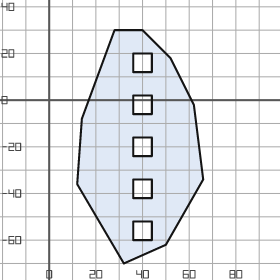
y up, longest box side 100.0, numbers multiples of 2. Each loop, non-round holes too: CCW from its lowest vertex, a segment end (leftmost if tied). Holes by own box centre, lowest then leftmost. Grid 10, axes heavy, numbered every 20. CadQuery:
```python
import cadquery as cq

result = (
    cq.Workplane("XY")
    .moveTo(32.0, -70.0)
    .lineTo(50.0, -62.0)
    .lineTo(66.0, -34.0)
    .lineTo(62.0, -2.0)
    .lineTo(52.0, 18.0)
    .lineTo(40.0, 30.0)
    .lineTo(28.0, 30.0)
    .lineTo(14.0, -8.0)
    .lineTo(12.0, -36.0)
    .close()
    .moveTo(36.0, -60.0)
    .lineTo(44.0, -60.0)
    .lineTo(44.0, -52.0)
    .lineTo(36.0, -52.0)
    .close()
    .moveTo(36.0, -42.0)
    .lineTo(44.0, -42.0)
    .lineTo(44.0, -34.0)
    .lineTo(36.0, -34.0)
    .close()
    .moveTo(36.0, -24.0)
    .lineTo(44.0, -24.0)
    .lineTo(44.0, -16.0)
    .lineTo(36.0, -16.0)
    .close()
    .moveTo(36.0, -6.0)
    .lineTo(44.0, -6.0)
    .lineTo(44.0, 2.0)
    .lineTo(36.0, 2.0)
    .close()
    .moveTo(36.0, 12.0)
    .lineTo(44.0, 12.0)
    .lineTo(44.0, 20.0)
    .lineTo(36.0, 20.0)
    .close()
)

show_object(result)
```